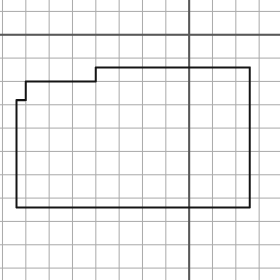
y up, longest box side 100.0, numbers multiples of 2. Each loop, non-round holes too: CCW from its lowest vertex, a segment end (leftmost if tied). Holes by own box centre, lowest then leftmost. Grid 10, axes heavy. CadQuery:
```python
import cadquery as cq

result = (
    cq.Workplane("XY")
    .moveTo(-74.0, -74.0)
    .lineTo(26.0, -74.0)
    .lineTo(26.0, -14.0)
    .lineTo(-40.0, -14.0)
    .lineTo(-40.0, -20.0)
    .lineTo(-70.0, -20.0)
    .lineTo(-70.0, -28.0)
    .lineTo(-74.0, -28.0)
    .close()
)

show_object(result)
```